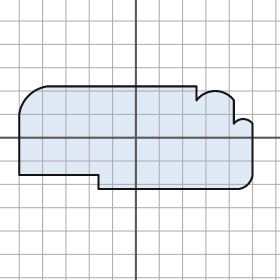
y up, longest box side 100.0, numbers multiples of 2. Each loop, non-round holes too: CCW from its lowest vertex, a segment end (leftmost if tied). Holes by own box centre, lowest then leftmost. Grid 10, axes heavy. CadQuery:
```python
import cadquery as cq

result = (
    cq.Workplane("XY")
    .moveTo(-16.0, -22.0)
    .lineTo(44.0, -22.0)
    .threePointArc((48.0, -20.0), (50.0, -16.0))
    .lineTo(50.0, 6.0)
    .threePointArc((46.0, 8.0), (42.0, 6.0))
    .lineTo(42.0, 16.0)
    .threePointArc((34.0, 20.0), (26.0, 16.0))
    .lineTo(26.0, 22.0)
    .lineTo(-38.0, 22.0)
    .threePointArc((-46.0, 18.0), (-50.0, 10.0))
    .lineTo(-50.0, -16.0)
    .lineTo(-16.0, -16.0)
    .close()
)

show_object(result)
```